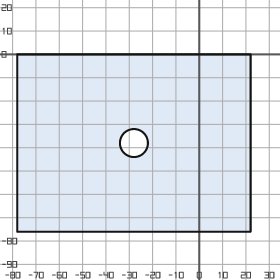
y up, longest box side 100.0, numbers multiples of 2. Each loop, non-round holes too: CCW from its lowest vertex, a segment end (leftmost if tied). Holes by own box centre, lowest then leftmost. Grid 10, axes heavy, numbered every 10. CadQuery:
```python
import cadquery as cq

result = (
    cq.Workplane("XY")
    .moveTo(-78.0, -76.0)
    .lineTo(22.0, -76.0)
    .lineTo(22.0, 0.0)
    .lineTo(-78.0, 0.0)
    .close()
    .moveTo(-28.0, -38.0)
    .circle(6.0)
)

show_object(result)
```